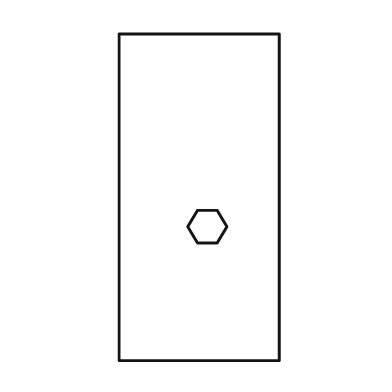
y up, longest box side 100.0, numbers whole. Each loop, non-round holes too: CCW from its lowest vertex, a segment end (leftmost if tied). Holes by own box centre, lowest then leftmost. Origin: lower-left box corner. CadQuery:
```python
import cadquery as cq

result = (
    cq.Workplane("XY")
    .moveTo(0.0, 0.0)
    .lineTo(49.0, 0.0)
    .lineTo(49.0, 100.0)
    .lineTo(0.0, 100.0)
    .close()
    .moveTo(24.0, 36.0)
    .lineTo(30.0, 36.0)
    .lineTo(33.0, 41.0)
    .lineTo(30.0, 46.0)
    .lineTo(24.0, 46.0)
    .lineTo(21.0, 41.0)
    .close()
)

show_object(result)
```